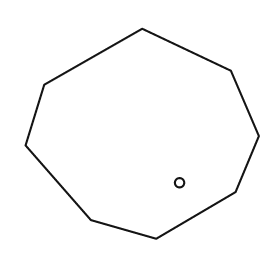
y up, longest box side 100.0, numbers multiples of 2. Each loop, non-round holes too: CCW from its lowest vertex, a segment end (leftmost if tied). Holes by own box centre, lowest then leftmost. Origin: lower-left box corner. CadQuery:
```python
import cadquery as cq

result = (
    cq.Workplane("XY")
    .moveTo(56.0, 0.0)
    .lineTo(90.0, 20.0)
    .lineTo(100.0, 44.0)
    .lineTo(88.0, 72.0)
    .lineTo(50.0, 90.0)
    .lineTo(8.0, 66.0)
    .lineTo(0.0, 40.0)
    .lineTo(28.0, 8.0)
    .close()
    .moveTo(66.0, 24.0)
    .circle(2.0)
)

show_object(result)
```